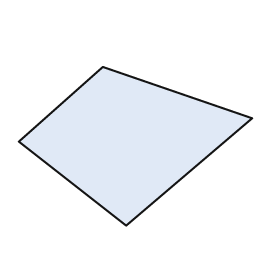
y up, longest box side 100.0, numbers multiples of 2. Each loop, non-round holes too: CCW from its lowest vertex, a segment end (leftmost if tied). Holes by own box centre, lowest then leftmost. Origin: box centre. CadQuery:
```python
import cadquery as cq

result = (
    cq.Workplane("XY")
    .moveTo(-4.0, -34.0)
    .lineTo(50.0, 12.0)
    .lineTo(-14.0, 34.0)
    .lineTo(-50.0, 2.0)
    .close()
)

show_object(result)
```